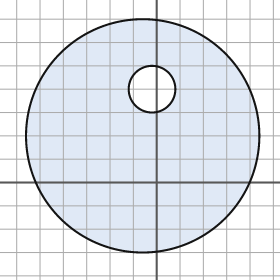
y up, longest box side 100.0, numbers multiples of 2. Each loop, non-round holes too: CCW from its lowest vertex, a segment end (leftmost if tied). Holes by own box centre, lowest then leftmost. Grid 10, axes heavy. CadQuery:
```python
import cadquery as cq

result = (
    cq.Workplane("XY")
    .moveTo(-6.0, 20.0)
    .circle(50.0)
    .moveTo(-2.0, 40.0)
    .circle(10.0)
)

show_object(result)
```